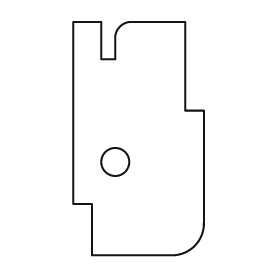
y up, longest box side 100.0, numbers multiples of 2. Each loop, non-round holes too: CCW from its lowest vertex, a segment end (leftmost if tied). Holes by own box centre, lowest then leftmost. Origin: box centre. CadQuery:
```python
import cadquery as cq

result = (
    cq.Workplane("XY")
    .moveTo(-20.0, -50.0)
    .lineTo(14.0, -50.0)
    .threePointArc((24.0, -46.0), (28.0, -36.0))
    .lineTo(28.0, 12.0)
    .lineTo(20.0, 12.0)
    .lineTo(20.0, 50.0)
    .lineTo(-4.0, 50.0)
    .threePointArc((-8.0, 48.0), (-10.0, 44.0))
    .lineTo(-10.0, 34.0)
    .lineTo(-16.0, 34.0)
    .lineTo(-16.0, 50.0)
    .lineTo(-28.0, 50.0)
    .lineTo(-28.0, -28.0)
    .lineTo(-20.0, -28.0)
    .close()
    .moveTo(-10.0, -10.0)
    .circle(6.0)
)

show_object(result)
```